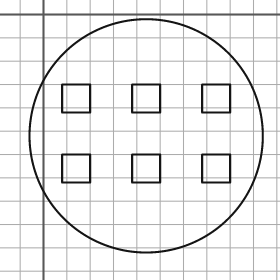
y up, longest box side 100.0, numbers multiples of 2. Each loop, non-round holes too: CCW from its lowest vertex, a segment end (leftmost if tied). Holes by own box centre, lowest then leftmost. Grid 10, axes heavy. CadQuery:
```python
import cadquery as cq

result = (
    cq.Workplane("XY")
    .moveTo(44.0, -52.0)
    .circle(50.0)
    .moveTo(8.0, -72.0)
    .lineTo(20.0, -72.0)
    .lineTo(20.0, -60.0)
    .lineTo(8.0, -60.0)
    .close()
    .moveTo(38.0, -72.0)
    .lineTo(50.0, -72.0)
    .lineTo(50.0, -60.0)
    .lineTo(38.0, -60.0)
    .close()
    .moveTo(68.0, -72.0)
    .lineTo(80.0, -72.0)
    .lineTo(80.0, -60.0)
    .lineTo(68.0, -60.0)
    .close()
    .moveTo(8.0, -42.0)
    .lineTo(20.0, -42.0)
    .lineTo(20.0, -30.0)
    .lineTo(8.0, -30.0)
    .close()
    .moveTo(38.0, -42.0)
    .lineTo(50.0, -42.0)
    .lineTo(50.0, -30.0)
    .lineTo(38.0, -30.0)
    .close()
    .moveTo(68.0, -42.0)
    .lineTo(80.0, -42.0)
    .lineTo(80.0, -30.0)
    .lineTo(68.0, -30.0)
    .close()
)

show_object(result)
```